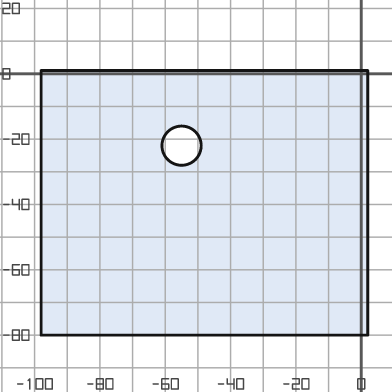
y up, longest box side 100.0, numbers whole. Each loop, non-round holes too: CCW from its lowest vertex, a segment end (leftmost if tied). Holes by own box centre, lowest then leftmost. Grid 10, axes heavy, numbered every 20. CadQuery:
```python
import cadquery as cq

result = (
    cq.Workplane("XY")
    .moveTo(-98.0, -80.0)
    .lineTo(2.0, -80.0)
    .lineTo(2.0, 1.0)
    .lineTo(-98.0, 1.0)
    .close()
    .moveTo(-55.0, -22.0)
    .circle(6.0)
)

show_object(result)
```